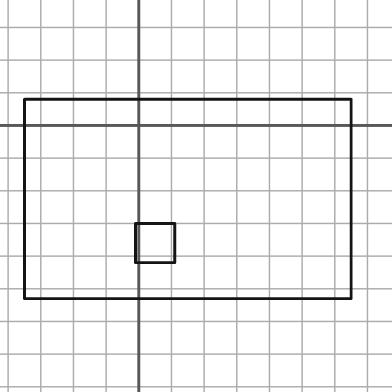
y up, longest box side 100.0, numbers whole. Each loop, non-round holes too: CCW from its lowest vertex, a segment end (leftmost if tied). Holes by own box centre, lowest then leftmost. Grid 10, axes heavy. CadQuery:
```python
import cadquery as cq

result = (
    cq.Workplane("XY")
    .moveTo(-35.0, -53.0)
    .lineTo(65.0, -53.0)
    .lineTo(65.0, 8.0)
    .lineTo(-35.0, 8.0)
    .close()
    .moveTo(-1.0, -42.0)
    .lineTo(11.0, -42.0)
    .lineTo(11.0, -30.0)
    .lineTo(-1.0, -30.0)
    .close()
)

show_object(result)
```